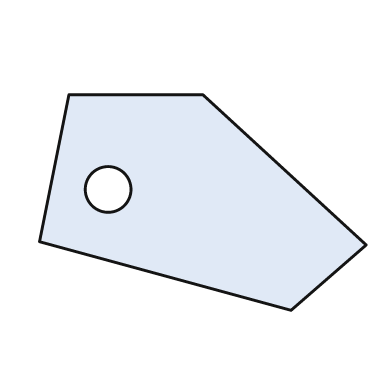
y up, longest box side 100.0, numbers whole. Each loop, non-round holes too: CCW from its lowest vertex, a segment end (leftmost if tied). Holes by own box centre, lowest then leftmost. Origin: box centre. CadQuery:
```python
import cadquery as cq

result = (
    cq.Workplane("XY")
    .moveTo(27.0, -33.0)
    .lineTo(50.0, -13.0)
    .lineTo(0.0, 33.0)
    .lineTo(-41.0, 33.0)
    .lineTo(-50.0, -12.0)
    .close()
    .moveTo(-29.0, 4.0)
    .circle(7.0)
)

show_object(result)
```